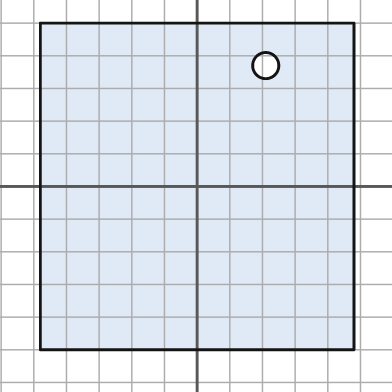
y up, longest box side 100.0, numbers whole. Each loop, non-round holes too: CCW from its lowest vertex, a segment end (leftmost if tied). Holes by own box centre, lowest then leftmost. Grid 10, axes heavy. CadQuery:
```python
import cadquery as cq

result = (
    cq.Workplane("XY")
    .moveTo(-48.0, -50.0)
    .lineTo(48.0, -50.0)
    .lineTo(48.0, 50.0)
    .lineTo(-48.0, 50.0)
    .close()
    .moveTo(21.0, 37.0)
    .circle(4.0)
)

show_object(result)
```